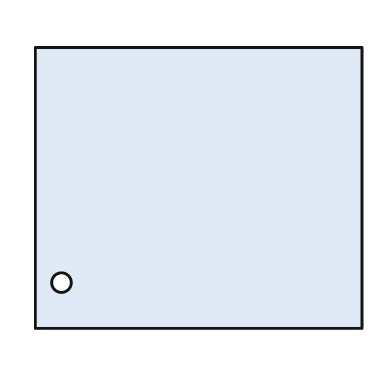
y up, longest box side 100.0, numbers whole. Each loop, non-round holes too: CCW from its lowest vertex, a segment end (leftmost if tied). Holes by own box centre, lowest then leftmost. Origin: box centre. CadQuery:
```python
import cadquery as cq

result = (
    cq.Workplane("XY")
    .moveTo(-50.0, -43.0)
    .lineTo(50.0, -43.0)
    .lineTo(50.0, 43.0)
    .lineTo(-50.0, 43.0)
    .close()
    .moveTo(-42.0, -29.0)
    .circle(3.0)
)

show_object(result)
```